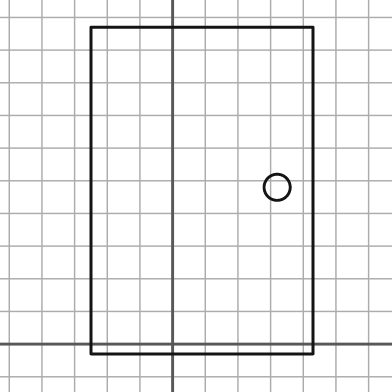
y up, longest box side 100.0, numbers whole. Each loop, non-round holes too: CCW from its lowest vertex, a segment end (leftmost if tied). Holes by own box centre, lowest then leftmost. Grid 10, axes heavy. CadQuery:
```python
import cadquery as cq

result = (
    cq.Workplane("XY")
    .moveTo(-25.0, -3.0)
    .lineTo(43.0, -3.0)
    .lineTo(43.0, 97.0)
    .lineTo(-25.0, 97.0)
    .close()
    .moveTo(32.0, 48.0)
    .circle(4.0)
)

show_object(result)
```